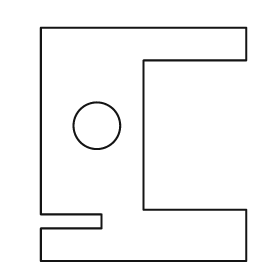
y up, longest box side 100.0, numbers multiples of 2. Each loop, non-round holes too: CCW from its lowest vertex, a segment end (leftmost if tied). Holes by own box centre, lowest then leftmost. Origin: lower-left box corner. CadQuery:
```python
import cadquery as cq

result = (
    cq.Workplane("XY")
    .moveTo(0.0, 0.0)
    .lineTo(88.0, 0.0)
    .lineTo(88.0, 22.0)
    .lineTo(44.0, 22.0)
    .lineTo(44.0, 86.0)
    .lineTo(88.0, 86.0)
    .lineTo(88.0, 100.0)
    .lineTo(0.0, 100.0)
    .lineTo(0.0, 20.0)
    .lineTo(26.0, 20.0)
    .lineTo(26.0, 14.0)
    .lineTo(0.0, 14.0)
    .close()
    .moveTo(24.0, 58.0)
    .circle(10.0)
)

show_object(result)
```